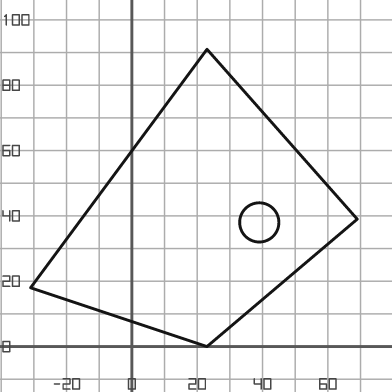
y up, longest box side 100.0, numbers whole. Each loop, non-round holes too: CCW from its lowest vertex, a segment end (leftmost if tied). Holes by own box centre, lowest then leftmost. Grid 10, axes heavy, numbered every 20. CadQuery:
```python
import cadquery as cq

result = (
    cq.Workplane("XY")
    .moveTo(23.0, 0.0)
    .lineTo(69.0, 39.0)
    .lineTo(23.0, 91.0)
    .lineTo(-31.0, 18.0)
    .close()
    .moveTo(39.0, 38.0)
    .circle(6.0)
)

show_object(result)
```